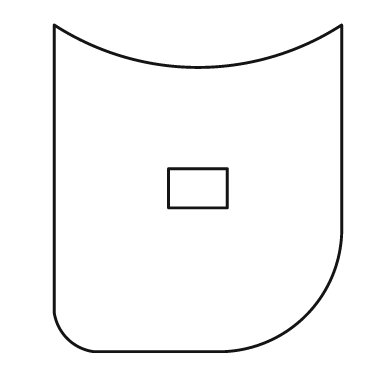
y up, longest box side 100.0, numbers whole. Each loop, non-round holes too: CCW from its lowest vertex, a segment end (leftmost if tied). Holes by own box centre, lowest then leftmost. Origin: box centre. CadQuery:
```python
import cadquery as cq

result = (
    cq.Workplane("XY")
    .moveTo(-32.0, -50.0)
    .lineTo(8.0, -50.0)
    .threePointArc((33.0, -39.0), (44.0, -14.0))
    .lineTo(44.0, 50.0)
    .threePointArc((0.0, 37.0), (-44.0, 50.0))
    .lineTo(-44.0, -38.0)
    .threePointArc((-40.0, -46.0), (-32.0, -50.0))
    .close()
    .moveTo(-9.0, -6.0)
    .lineTo(9.0, -6.0)
    .lineTo(9.0, 6.0)
    .lineTo(-9.0, 6.0)
    .close()
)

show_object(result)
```